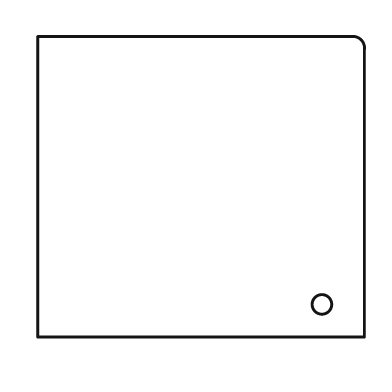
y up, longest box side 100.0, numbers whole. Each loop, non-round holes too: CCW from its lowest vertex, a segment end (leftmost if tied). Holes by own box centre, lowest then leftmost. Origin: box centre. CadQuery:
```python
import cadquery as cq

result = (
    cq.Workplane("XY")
    .moveTo(-50.0, -46.0)
    .lineTo(50.0, -46.0)
    .lineTo(50.0, 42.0)
    .threePointArc((49.0, 45.0), (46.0, 46.0))
    .lineTo(-50.0, 46.0)
    .close()
    .moveTo(37.0, -36.0)
    .circle(3.0)
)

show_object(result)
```